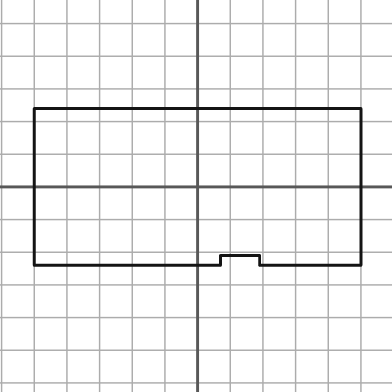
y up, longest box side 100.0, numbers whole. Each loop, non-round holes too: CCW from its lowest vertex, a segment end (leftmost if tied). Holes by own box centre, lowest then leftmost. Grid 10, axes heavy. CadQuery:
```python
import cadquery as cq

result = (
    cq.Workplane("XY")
    .moveTo(-50.0, -24.0)
    .lineTo(7.0, -24.0)
    .lineTo(7.0, -21.0)
    .lineTo(19.0, -21.0)
    .lineTo(19.0, -24.0)
    .lineTo(50.0, -24.0)
    .lineTo(50.0, 24.0)
    .lineTo(-50.0, 24.0)
    .close()
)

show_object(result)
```